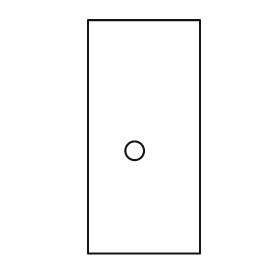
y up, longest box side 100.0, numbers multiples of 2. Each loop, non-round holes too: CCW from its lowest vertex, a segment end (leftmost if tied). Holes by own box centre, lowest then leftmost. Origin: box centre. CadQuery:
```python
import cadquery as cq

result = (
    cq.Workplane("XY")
    .moveTo(-24.0, -50.0)
    .lineTo(24.0, -50.0)
    .lineTo(24.0, 50.0)
    .lineTo(-24.0, 50.0)
    .close()
    .moveTo(-4.0, -6.0)
    .circle(4.0)
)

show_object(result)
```